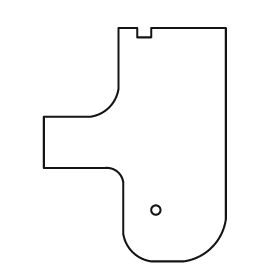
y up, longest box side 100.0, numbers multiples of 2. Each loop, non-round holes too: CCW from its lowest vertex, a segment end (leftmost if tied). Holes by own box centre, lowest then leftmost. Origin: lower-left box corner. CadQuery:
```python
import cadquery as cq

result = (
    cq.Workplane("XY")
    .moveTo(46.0, 0.0)
    .lineTo(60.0, 0.0)
    .threePointArc((72.0, 6.0), (78.0, 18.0))
    .lineTo(78.0, 100.0)
    .lineTo(46.0, 100.0)
    .lineTo(46.0, 96.0)
    .lineTo(40.0, 96.0)
    .lineTo(40.0, 100.0)
    .lineTo(32.0, 100.0)
    .lineTo(32.0, 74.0)
    .threePointArc((28.0, 66.0), (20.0, 62.0))
    .lineTo(0.0, 62.0)
    .lineTo(0.0, 40.0)
    .lineTo(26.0, 40.0)
    .threePointArc((32.0, 38.0), (34.0, 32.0))
    .lineTo(34.0, 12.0)
    .threePointArc((38.0, 4.0), (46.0, 0.0))
    .close()
    .moveTo(48.0, 22.0)
    .circle(2.0)
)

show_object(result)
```